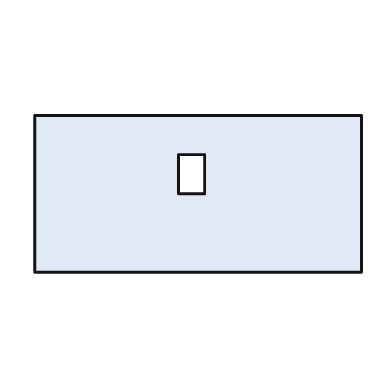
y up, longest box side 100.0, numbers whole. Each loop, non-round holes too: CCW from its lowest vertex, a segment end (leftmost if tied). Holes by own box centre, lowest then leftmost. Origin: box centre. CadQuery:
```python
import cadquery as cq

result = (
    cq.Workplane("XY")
    .moveTo(-50.0, -24.0)
    .lineTo(50.0, -24.0)
    .lineTo(50.0, 24.0)
    .lineTo(-50.0, 24.0)
    .close()
    .moveTo(-6.0, 0.0)
    .lineTo(2.0, 0.0)
    .lineTo(2.0, 12.0)
    .lineTo(-6.0, 12.0)
    .close()
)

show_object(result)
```